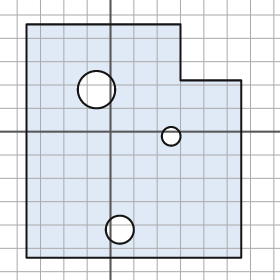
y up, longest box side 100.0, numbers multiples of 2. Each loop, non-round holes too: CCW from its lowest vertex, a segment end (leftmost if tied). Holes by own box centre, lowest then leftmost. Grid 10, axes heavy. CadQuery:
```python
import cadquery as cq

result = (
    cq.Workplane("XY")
    .moveTo(-36.0, -54.0)
    .lineTo(56.0, -54.0)
    .lineTo(56.0, 22.0)
    .lineTo(30.0, 22.0)
    .lineTo(30.0, 46.0)
    .lineTo(-36.0, 46.0)
    .close()
    .moveTo(4.0, -42.0)
    .circle(6.0)
    .moveTo(26.0, -2.0)
    .circle(4.0)
    .moveTo(-6.0, 18.0)
    .circle(8.0)
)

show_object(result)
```